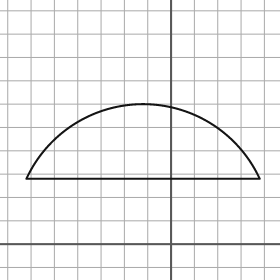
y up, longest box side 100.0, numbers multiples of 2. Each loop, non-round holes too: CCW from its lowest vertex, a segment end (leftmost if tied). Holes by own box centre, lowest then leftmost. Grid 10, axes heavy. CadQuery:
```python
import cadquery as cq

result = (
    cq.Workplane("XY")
    .moveTo(-62.0, 28.0)
    .lineTo(38.0, 28.0)
    .threePointArc((-12.0, 60.0), (-62.0, 28.0))
    .close()
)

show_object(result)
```